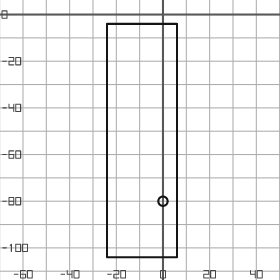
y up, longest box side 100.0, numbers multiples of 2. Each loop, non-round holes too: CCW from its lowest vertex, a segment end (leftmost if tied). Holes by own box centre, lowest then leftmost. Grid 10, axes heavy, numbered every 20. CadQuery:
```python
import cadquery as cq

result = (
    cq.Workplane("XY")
    .moveTo(-24.0, -104.0)
    .lineTo(6.0, -104.0)
    .lineTo(6.0, -4.0)
    .lineTo(-24.0, -4.0)
    .close()
    .moveTo(0.0, -80.0)
    .circle(2.0)
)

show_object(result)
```